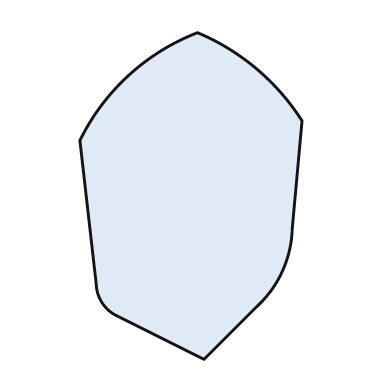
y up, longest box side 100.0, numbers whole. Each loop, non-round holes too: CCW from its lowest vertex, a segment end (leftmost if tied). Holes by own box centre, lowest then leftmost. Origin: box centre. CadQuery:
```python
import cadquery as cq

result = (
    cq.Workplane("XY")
    .moveTo(4.0, -50.0)
    .lineTo(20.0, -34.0)
    .threePointArc((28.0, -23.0), (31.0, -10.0))
    .lineTo(34.0, 23.0)
    .threePointArc((20.0, 39.0), (2.0, 50.0))
    .threePointArc((-19.0, 37.0), (-34.0, 17.0))
    .lineTo(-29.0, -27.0)
    .threePointArc((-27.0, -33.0), (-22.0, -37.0))
    .close()
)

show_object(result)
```